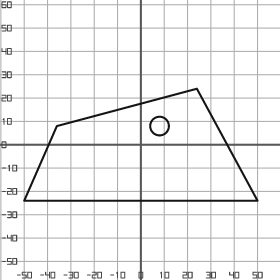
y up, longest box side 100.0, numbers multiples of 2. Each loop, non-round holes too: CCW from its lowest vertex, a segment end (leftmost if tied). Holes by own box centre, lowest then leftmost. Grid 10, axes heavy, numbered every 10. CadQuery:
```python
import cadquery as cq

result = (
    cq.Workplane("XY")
    .moveTo(-50.0, -24.0)
    .lineTo(50.0, -24.0)
    .lineTo(24.0, 24.0)
    .lineTo(-36.0, 8.0)
    .close()
    .moveTo(8.0, 8.0)
    .circle(4.0)
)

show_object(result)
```